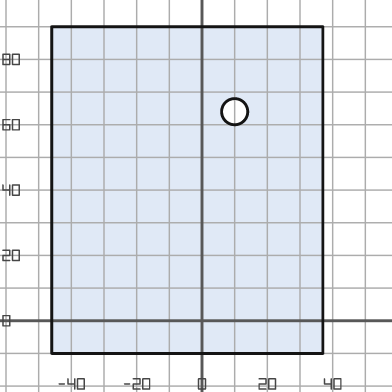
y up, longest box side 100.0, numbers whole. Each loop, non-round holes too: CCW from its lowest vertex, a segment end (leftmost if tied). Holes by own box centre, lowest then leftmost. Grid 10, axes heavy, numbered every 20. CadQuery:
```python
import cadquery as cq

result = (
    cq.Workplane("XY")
    .moveTo(-46.0, -10.0)
    .lineTo(37.0, -10.0)
    .lineTo(37.0, 90.0)
    .lineTo(-46.0, 90.0)
    .close()
    .moveTo(10.0, 64.0)
    .circle(4.0)
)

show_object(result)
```